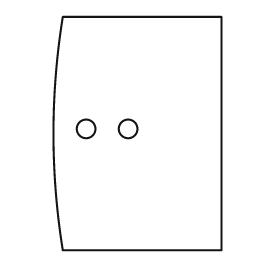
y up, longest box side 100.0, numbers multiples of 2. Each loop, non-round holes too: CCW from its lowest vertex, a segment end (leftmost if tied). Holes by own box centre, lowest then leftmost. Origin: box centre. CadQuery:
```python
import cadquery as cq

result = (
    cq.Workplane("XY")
    .moveTo(-32.0, -50.0)
    .lineTo(36.0, -50.0)
    .lineTo(36.0, 50.0)
    .lineTo(-32.0, 50.0)
    .threePointArc((-36.0, 0.0), (-32.0, -50.0))
    .close()
    .moveTo(-22.0, 2.0)
    .circle(4.0)
    .moveTo(-4.0, 2.0)
    .circle(4.0)
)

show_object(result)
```